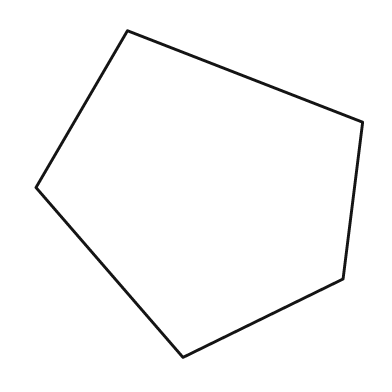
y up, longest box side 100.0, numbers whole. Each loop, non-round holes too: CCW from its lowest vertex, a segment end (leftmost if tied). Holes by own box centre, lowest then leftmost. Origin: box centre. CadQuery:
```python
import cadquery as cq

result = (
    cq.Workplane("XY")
    .moveTo(-5.0, -50.0)
    .lineTo(44.0, -26.0)
    .lineTo(50.0, 22.0)
    .lineTo(-22.0, 50.0)
    .lineTo(-50.0, 2.0)
    .close()
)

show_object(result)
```